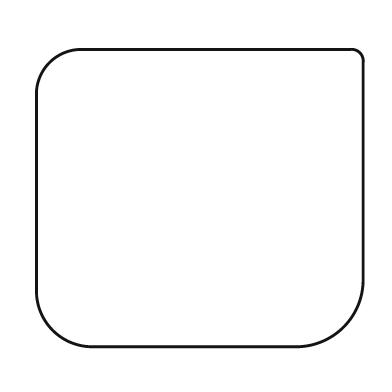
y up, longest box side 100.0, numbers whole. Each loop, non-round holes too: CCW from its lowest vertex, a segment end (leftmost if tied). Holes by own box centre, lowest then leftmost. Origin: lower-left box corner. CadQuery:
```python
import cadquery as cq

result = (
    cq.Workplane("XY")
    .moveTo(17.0, 0.0)
    .lineTo(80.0, 0.0)
    .threePointArc((94.0, 6.0), (100.0, 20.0))
    .lineTo(100.0, 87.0)
    .threePointArc((99.0, 90.0), (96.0, 91.0))
    .lineTo(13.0, 91.0)
    .threePointArc((4.0, 87.0), (0.0, 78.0))
    .lineTo(0.0, 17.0)
    .threePointArc((5.0, 5.0), (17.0, 0.0))
    .close()
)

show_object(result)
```